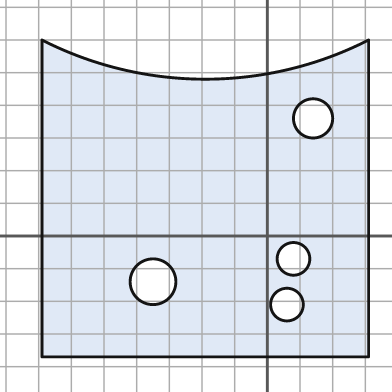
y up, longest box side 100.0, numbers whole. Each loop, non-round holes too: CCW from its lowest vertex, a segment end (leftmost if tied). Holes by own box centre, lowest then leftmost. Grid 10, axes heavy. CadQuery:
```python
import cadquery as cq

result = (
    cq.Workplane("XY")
    .moveTo(-69.0, -37.0)
    .lineTo(31.0, -37.0)
    .lineTo(31.0, 60.0)
    .threePointArc((-19.0, 48.0), (-69.0, 60.0))
    .close()
    .moveTo(6.0, -21.0)
    .circle(5.0)
    .moveTo(-35.0, -14.0)
    .circle(7.0)
    .moveTo(8.0, -7.0)
    .circle(5.0)
    .moveTo(14.0, 36.0)
    .circle(6.0)
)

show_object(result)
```